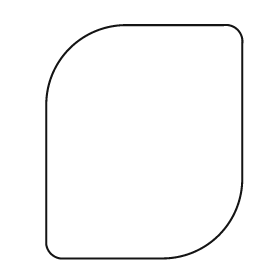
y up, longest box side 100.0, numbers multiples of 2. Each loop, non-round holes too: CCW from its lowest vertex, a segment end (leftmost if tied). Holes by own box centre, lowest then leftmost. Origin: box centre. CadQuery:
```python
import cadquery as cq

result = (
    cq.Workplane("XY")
    .moveTo(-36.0, -50.0)
    .lineTo(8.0, -50.0)
    .threePointArc((32.0, -40.0), (42.0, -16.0))
    .lineTo(42.0, 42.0)
    .threePointArc((40.0, 48.0), (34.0, 50.0))
    .lineTo(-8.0, 50.0)
    .threePointArc((-32.0, 40.0), (-42.0, 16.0))
    .lineTo(-42.0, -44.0)
    .threePointArc((-40.0, -48.0), (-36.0, -50.0))
    .close()
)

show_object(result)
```